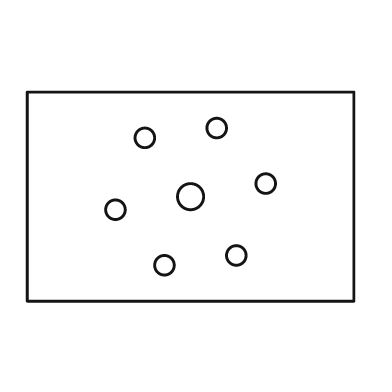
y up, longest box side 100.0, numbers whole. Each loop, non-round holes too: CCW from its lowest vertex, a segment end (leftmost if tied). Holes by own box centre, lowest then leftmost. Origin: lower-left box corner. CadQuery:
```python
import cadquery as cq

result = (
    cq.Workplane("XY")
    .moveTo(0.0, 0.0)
    .lineTo(100.0, 0.0)
    .lineTo(100.0, 64.0)
    .lineTo(0.0, 64.0)
    .close()
    .moveTo(42.0, 11.0)
    .circle(3.0)
    .moveTo(64.0, 14.0)
    .circle(3.0)
    .moveTo(27.0, 28.0)
    .circle(3.0)
    .moveTo(50.0, 32.0)
    .circle(4.0)
    .moveTo(73.0, 36.0)
    .circle(3.0)
    .moveTo(36.0, 50.0)
    .circle(3.0)
    .moveTo(58.0, 53.0)
    .circle(3.0)
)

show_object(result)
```